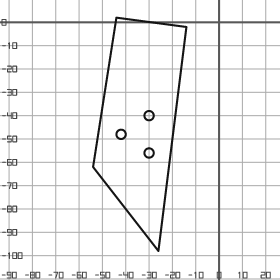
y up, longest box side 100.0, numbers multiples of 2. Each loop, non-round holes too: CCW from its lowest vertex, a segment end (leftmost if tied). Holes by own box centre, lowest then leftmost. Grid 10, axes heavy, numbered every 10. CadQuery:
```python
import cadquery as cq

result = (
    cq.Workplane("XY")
    .moveTo(-26.0, -98.0)
    .lineTo(-14.0, -2.0)
    .lineTo(-44.0, 2.0)
    .lineTo(-54.0, -62.0)
    .close()
    .moveTo(-30.0, -56.0)
    .circle(2.0)
    .moveTo(-42.0, -48.0)
    .circle(2.0)
    .moveTo(-30.0, -40.0)
    .circle(2.0)
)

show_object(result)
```